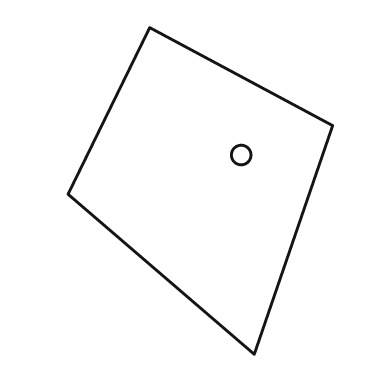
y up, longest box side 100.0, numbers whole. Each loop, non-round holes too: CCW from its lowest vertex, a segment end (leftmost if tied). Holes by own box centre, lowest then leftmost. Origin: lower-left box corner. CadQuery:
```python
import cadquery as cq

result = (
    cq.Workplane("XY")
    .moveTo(57.0, 0.0)
    .lineTo(81.0, 70.0)
    .lineTo(25.0, 100.0)
    .lineTo(0.0, 49.0)
    .close()
    .moveTo(53.0, 61.0)
    .circle(3.0)
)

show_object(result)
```